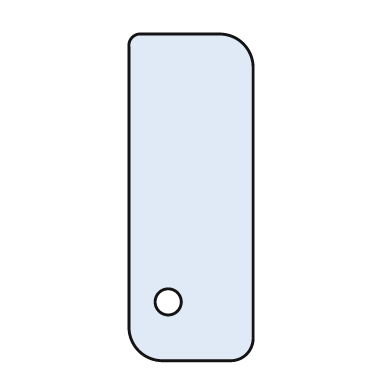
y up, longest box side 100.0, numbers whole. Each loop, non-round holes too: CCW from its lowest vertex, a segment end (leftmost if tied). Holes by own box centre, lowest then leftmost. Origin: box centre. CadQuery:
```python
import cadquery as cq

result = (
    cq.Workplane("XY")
    .moveTo(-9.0, -50.0)
    .lineTo(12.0, -50.0)
    .threePointArc((17.0, -48.0), (19.0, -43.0))
    .lineTo(19.0, 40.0)
    .threePointArc((16.0, 47.0), (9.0, 50.0))
    .lineTo(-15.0, 50.0)
    .threePointArc((-18.0, 49.0), (-19.0, 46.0))
    .lineTo(-19.0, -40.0)
    .threePointArc((-16.0, -47.0), (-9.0, -50.0))
    .close()
    .moveTo(-7.0, -32.0)
    .circle(4.0)
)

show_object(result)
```